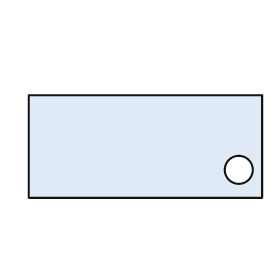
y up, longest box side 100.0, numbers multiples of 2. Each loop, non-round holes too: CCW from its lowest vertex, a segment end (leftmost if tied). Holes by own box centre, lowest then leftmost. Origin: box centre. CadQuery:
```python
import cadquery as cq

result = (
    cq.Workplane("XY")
    .moveTo(-50.0, -22.0)
    .lineTo(50.0, -22.0)
    .lineTo(50.0, 22.0)
    .lineTo(-50.0, 22.0)
    .close()
    .moveTo(40.0, -10.0)
    .circle(6.0)
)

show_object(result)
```